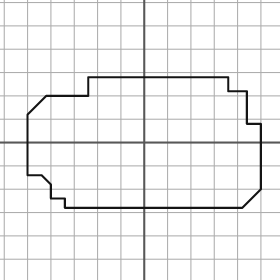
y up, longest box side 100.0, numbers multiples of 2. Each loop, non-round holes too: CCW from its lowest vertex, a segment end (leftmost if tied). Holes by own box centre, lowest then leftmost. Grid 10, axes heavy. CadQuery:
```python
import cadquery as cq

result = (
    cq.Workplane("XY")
    .moveTo(-34.0, -28.0)
    .lineTo(42.0, -28.0)
    .lineTo(50.0, -20.0)
    .lineTo(50.0, 8.0)
    .lineTo(44.0, 8.0)
    .lineTo(44.0, 22.0)
    .lineTo(36.0, 22.0)
    .lineTo(36.0, 28.0)
    .lineTo(-24.0, 28.0)
    .lineTo(-24.0, 20.0)
    .lineTo(-42.0, 20.0)
    .lineTo(-50.0, 12.0)
    .lineTo(-50.0, -14.0)
    .lineTo(-44.0, -14.0)
    .lineTo(-40.0, -18.0)
    .lineTo(-40.0, -24.0)
    .lineTo(-34.0, -24.0)
    .close()
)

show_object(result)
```